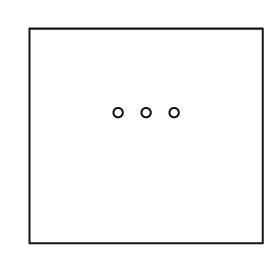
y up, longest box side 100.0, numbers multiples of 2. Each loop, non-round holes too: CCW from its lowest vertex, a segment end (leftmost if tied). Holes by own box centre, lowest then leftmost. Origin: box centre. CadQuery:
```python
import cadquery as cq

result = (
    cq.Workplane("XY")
    .moveTo(-50.0, -46.0)
    .lineTo(50.0, -46.0)
    .lineTo(50.0, 46.0)
    .lineTo(-50.0, 46.0)
    .close()
    .moveTo(-12.0, 10.0)
    .circle(2.0)
    .moveTo(0.0, 10.0)
    .circle(2.0)
    .moveTo(12.0, 10.0)
    .circle(2.0)
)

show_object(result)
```